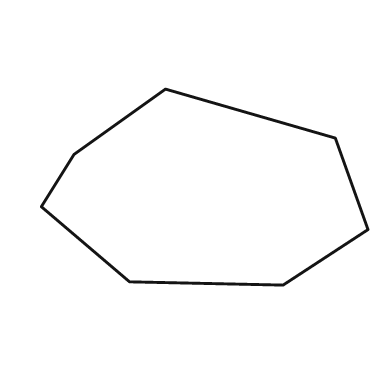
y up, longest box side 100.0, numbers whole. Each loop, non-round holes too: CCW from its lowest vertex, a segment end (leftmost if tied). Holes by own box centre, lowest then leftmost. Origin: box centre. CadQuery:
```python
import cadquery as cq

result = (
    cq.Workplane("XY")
    .moveTo(24.0, -30.0)
    .lineTo(50.0, -13.0)
    .lineTo(40.0, 15.0)
    .lineTo(-12.0, 30.0)
    .lineTo(-40.0, 10.0)
    .lineTo(-50.0, -6.0)
    .lineTo(-23.0, -29.0)
    .close()
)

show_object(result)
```